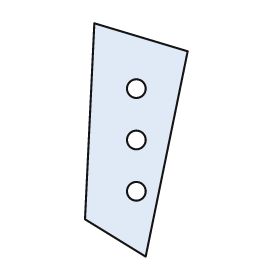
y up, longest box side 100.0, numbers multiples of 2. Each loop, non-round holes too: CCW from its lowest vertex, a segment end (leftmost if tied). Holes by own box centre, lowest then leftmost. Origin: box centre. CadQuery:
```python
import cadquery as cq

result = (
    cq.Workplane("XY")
    .moveTo(4.0, -50.0)
    .lineTo(22.0, 38.0)
    .lineTo(-18.0, 50.0)
    .lineTo(-22.0, -34.0)
    .close()
    .moveTo(0.0, -22.0)
    .circle(4.0)
    .moveTo(0.0, 0.0)
    .circle(4.0)
    .moveTo(0.0, 22.0)
    .circle(4.0)
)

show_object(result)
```